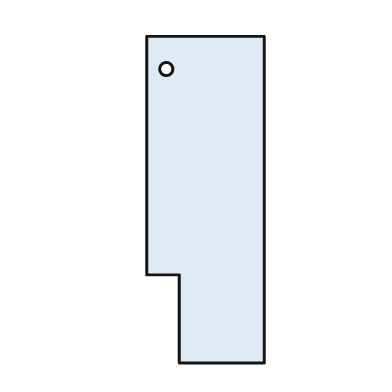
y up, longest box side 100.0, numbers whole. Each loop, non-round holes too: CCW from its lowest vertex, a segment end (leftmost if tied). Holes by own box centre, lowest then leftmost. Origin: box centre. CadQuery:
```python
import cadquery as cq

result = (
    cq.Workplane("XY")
    .moveTo(-8.0, -50.0)
    .lineTo(18.0, -50.0)
    .lineTo(18.0, 50.0)
    .lineTo(-18.0, 50.0)
    .lineTo(-18.0, -23.0)
    .lineTo(-8.0, -23.0)
    .close()
    .moveTo(-12.0, 40.0)
    .circle(2.0)
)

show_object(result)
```